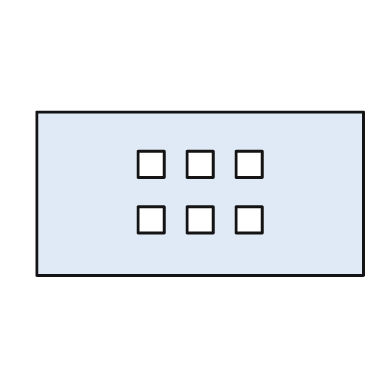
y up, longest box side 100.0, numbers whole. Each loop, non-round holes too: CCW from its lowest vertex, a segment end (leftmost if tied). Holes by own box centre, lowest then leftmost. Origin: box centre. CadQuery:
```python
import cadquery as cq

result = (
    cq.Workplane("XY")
    .moveTo(-50.0, -25.0)
    .lineTo(50.0, -25.0)
    .lineTo(50.0, 25.0)
    .lineTo(-50.0, 25.0)
    .close()
    .moveTo(-19.0, -12.0)
    .lineTo(-11.0, -12.0)
    .lineTo(-11.0, -4.0)
    .lineTo(-19.0, -4.0)
    .close()
    .moveTo(-4.0, -12.0)
    .lineTo(4.0, -12.0)
    .lineTo(4.0, -4.0)
    .lineTo(-4.0, -4.0)
    .close()
    .moveTo(11.0, -12.0)
    .lineTo(19.0, -12.0)
    .lineTo(19.0, -4.0)
    .lineTo(11.0, -4.0)
    .close()
    .moveTo(-19.0, 5.0)
    .lineTo(-11.0, 5.0)
    .lineTo(-11.0, 13.0)
    .lineTo(-19.0, 13.0)
    .close()
    .moveTo(-4.0, 5.0)
    .lineTo(4.0, 5.0)
    .lineTo(4.0, 13.0)
    .lineTo(-4.0, 13.0)
    .close()
    .moveTo(11.0, 5.0)
    .lineTo(19.0, 5.0)
    .lineTo(19.0, 13.0)
    .lineTo(11.0, 13.0)
    .close()
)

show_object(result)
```